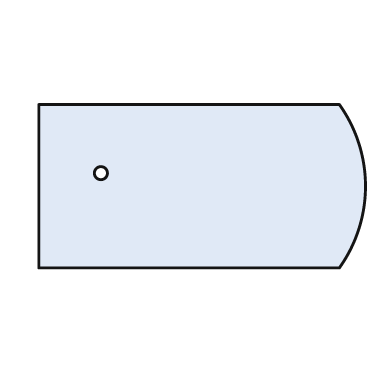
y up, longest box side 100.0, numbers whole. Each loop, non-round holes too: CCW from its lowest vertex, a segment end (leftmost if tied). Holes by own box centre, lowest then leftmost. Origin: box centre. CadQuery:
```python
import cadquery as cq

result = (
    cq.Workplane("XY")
    .moveTo(-50.0, -25.0)
    .lineTo(42.0, -25.0)
    .threePointArc((50.0, 0.0), (42.0, 25.0))
    .lineTo(-50.0, 25.0)
    .close()
    .moveTo(-31.0, 4.0)
    .circle(2.0)
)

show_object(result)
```